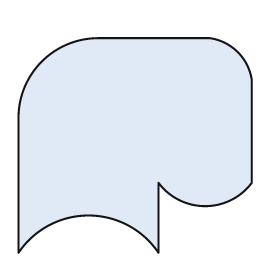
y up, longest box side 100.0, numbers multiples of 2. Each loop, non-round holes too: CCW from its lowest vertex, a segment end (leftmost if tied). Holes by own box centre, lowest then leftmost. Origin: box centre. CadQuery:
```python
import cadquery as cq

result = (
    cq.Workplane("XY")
    .moveTo(-50.0, -46.0)
    .threePointArc((-20.0, -30.0), (10.0, -46.0))
    .lineTo(10.0, -16.0)
    .threePointArc((30.0, -26.0), (50.0, -16.0))
    .lineTo(50.0, 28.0)
    .threePointArc((44.0, 40.0), (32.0, 46.0))
    .lineTo(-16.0, 46.0)
    .threePointArc((-40.0, 36.0), (-50.0, 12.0))
    .close()
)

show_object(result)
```